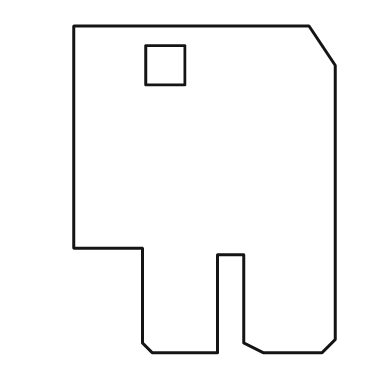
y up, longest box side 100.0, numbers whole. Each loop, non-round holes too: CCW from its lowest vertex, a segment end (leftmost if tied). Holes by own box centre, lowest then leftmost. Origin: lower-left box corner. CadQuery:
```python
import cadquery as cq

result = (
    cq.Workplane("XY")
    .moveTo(24.0, 0.0)
    .lineTo(44.0, 0.0)
    .lineTo(44.0, 30.0)
    .lineTo(52.0, 30.0)
    .lineTo(52.0, 3.0)
    .lineTo(58.0, 0.0)
    .lineTo(76.0, 0.0)
    .lineTo(80.0, 4.0)
    .lineTo(80.0, 88.0)
    .lineTo(72.0, 100.0)
    .lineTo(0.0, 100.0)
    .lineTo(0.0, 32.0)
    .lineTo(21.0, 32.0)
    .lineTo(21.0, 3.0)
    .close()
    .moveTo(22.0, 82.0)
    .lineTo(34.0, 82.0)
    .lineTo(34.0, 94.0)
    .lineTo(22.0, 94.0)
    .close()
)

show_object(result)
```